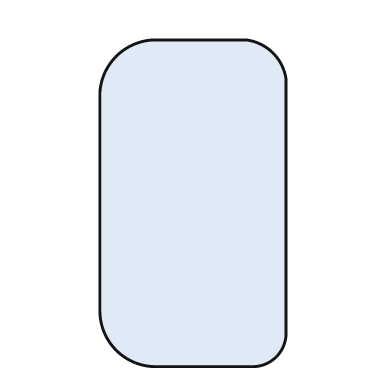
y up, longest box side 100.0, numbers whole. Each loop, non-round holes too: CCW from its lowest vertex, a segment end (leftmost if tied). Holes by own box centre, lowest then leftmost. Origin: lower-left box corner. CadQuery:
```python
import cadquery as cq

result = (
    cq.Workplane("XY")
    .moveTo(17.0, 0.0)
    .lineTo(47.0, 0.0)
    .threePointArc((54.0, 3.0), (57.0, 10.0))
    .lineTo(57.0, 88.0)
    .threePointArc((53.0, 96.0), (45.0, 100.0))
    .lineTo(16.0, 100.0)
    .threePointArc((5.0, 95.0), (0.0, 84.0))
    .lineTo(0.0, 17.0)
    .threePointArc((5.0, 5.0), (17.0, 0.0))
    .close()
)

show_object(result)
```